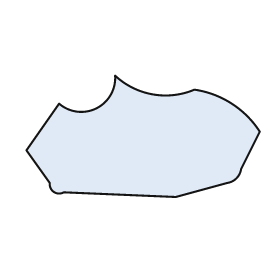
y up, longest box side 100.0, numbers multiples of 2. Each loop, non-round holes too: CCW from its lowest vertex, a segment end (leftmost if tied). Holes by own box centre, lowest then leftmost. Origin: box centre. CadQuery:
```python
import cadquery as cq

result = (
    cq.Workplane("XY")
    .moveTo(14.0, -26.0)
    .lineTo(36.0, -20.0)
    .threePointArc((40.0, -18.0), (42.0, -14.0))
    .lineTo(50.0, 2.0)
    .threePointArc((38.0, 14.0), (22.0, 20.0))
    .threePointArc((4.0, 18.0), (-12.0, 26.0))
    .threePointArc((-20.0, 12.0), (-36.0, 14.0))
    .lineTo(-50.0, -6.0)
    .lineTo(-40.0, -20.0)
    .threePointArc((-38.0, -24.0), (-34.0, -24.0))
    .close()
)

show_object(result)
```